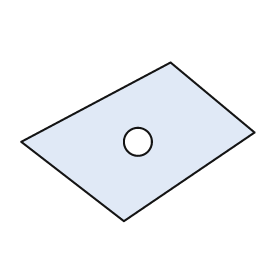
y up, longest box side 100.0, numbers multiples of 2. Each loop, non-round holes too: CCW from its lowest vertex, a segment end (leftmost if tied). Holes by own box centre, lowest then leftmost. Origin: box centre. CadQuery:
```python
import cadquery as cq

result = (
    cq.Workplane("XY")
    .moveTo(-6.0, -34.0)
    .lineTo(50.0, 4.0)
    .lineTo(14.0, 34.0)
    .lineTo(-50.0, 0.0)
    .close()
    .moveTo(0.0, 0.0)
    .circle(6.0)
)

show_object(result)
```